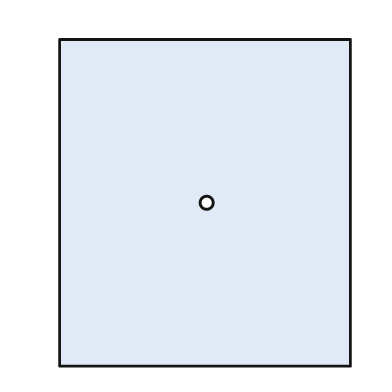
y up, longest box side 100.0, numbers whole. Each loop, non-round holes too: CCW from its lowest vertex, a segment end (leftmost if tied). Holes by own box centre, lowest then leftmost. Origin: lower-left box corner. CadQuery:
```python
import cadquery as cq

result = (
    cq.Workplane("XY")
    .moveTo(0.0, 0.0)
    .lineTo(89.0, 0.0)
    .lineTo(89.0, 100.0)
    .lineTo(0.0, 100.0)
    .close()
    .moveTo(45.0, 50.0)
    .circle(2.0)
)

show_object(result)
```